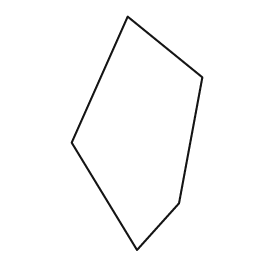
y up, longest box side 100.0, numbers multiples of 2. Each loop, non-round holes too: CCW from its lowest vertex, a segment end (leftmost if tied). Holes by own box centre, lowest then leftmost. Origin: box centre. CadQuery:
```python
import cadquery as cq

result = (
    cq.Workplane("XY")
    .moveTo(0.0, -50.0)
    .lineTo(18.0, -30.0)
    .lineTo(28.0, 24.0)
    .lineTo(-4.0, 50.0)
    .lineTo(-28.0, -4.0)
    .close()
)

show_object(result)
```